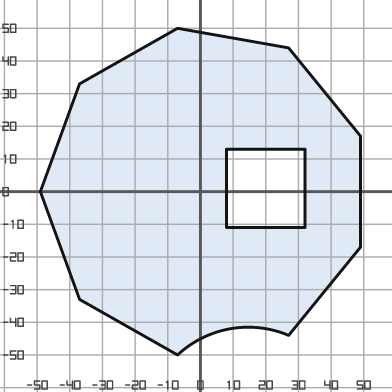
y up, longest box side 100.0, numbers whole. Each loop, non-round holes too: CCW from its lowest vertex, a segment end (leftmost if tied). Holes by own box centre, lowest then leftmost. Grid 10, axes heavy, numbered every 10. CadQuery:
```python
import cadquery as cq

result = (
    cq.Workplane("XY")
    .moveTo(-7.0, -50.0)
    .threePointArc((9.0, -42.0), (27.0, -44.0))
    .lineTo(49.0, -17.0)
    .lineTo(49.0, 17.0)
    .lineTo(27.0, 44.0)
    .lineTo(-7.0, 50.0)
    .lineTo(-37.0, 33.0)
    .lineTo(-49.0, 0.0)
    .lineTo(-37.0, -33.0)
    .close()
    .moveTo(8.0, -11.0)
    .lineTo(32.0, -11.0)
    .lineTo(32.0, 13.0)
    .lineTo(8.0, 13.0)
    .close()
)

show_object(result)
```